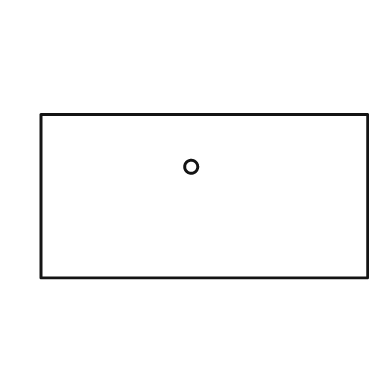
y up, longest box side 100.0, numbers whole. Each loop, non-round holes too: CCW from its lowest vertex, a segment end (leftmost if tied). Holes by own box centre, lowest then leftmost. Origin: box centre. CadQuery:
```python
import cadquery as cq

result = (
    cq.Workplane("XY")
    .moveTo(-50.0, -25.0)
    .lineTo(50.0, -25.0)
    .lineTo(50.0, 25.0)
    .lineTo(-50.0, 25.0)
    .close()
    .moveTo(-4.0, 9.0)
    .circle(2.0)
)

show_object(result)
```